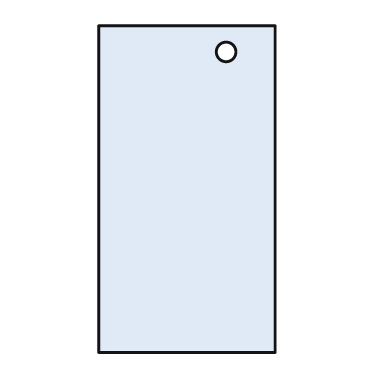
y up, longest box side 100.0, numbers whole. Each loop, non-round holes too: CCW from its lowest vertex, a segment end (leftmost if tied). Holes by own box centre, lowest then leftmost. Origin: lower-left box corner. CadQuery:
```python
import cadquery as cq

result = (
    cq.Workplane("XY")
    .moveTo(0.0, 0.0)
    .lineTo(54.0, 0.0)
    .lineTo(54.0, 100.0)
    .lineTo(0.0, 100.0)
    .close()
    .moveTo(39.0, 92.0)
    .circle(3.0)
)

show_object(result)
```